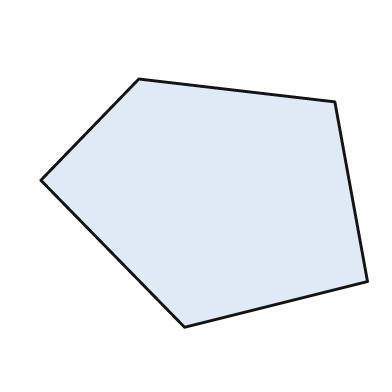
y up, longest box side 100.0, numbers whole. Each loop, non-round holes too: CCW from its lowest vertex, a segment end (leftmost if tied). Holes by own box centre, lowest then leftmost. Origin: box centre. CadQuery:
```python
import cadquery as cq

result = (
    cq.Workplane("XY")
    .moveTo(-6.0, -38.0)
    .lineTo(50.0, -24.0)
    .lineTo(40.0, 31.0)
    .lineTo(-20.0, 38.0)
    .lineTo(-50.0, 7.0)
    .close()
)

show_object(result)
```